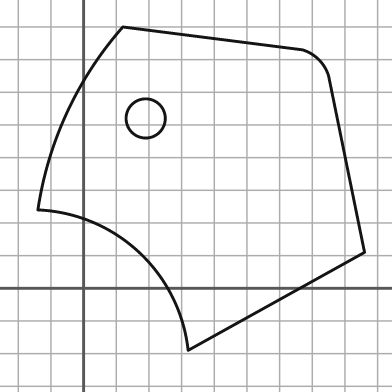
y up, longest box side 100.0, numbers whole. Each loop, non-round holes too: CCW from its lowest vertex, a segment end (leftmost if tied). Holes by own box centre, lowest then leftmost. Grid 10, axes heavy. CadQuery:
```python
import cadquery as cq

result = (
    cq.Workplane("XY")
    .moveTo(32.0, -19.0)
    .lineTo(86.0, 11.0)
    .lineTo(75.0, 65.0)
    .threePointArc((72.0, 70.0), (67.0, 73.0))
    .lineTo(12.0, 80.0)
    .threePointArc((-5.0, 54.0), (-14.0, 24.0))
    .threePointArc((17.0, 11.0), (32.0, -19.0))
    .close()
    .moveTo(19.0, 52.0)
    .circle(6.0)
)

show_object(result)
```